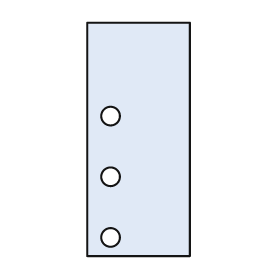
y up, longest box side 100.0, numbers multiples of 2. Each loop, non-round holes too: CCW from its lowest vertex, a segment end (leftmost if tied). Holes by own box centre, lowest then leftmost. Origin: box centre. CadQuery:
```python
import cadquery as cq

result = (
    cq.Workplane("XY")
    .moveTo(-22.0, -50.0)
    .lineTo(22.0, -50.0)
    .lineTo(22.0, 50.0)
    .lineTo(-22.0, 50.0)
    .close()
    .moveTo(-12.0, -42.0)
    .circle(4.0)
    .moveTo(-12.0, -16.0)
    .circle(4.0)
    .moveTo(-12.0, 10.0)
    .circle(4.0)
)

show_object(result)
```